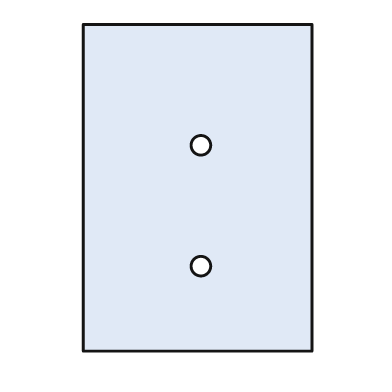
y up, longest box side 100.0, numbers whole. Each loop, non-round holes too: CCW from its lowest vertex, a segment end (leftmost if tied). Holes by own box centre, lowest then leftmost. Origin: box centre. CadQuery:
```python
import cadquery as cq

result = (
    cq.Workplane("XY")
    .moveTo(-35.0, -50.0)
    .lineTo(35.0, -50.0)
    .lineTo(35.0, 50.0)
    .lineTo(-35.0, 50.0)
    .close()
    .moveTo(1.0, -24.0)
    .circle(3.0)
    .moveTo(1.0, 13.0)
    .circle(3.0)
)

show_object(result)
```